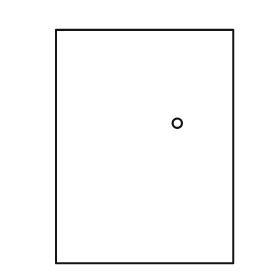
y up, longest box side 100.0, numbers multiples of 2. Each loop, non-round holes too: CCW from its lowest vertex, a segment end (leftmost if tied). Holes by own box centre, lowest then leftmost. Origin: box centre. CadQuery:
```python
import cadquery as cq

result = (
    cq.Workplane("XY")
    .moveTo(-38.0, -50.0)
    .lineTo(38.0, -50.0)
    .lineTo(38.0, 50.0)
    .lineTo(-38.0, 50.0)
    .close()
    .moveTo(14.0, 10.0)
    .circle(2.0)
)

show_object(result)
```